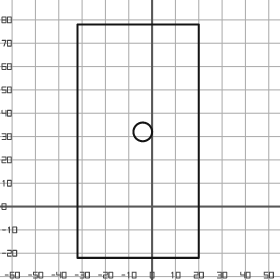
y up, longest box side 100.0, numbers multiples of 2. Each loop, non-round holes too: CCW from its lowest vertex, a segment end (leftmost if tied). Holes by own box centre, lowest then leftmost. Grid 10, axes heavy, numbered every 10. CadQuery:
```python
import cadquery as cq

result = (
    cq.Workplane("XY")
    .moveTo(-32.0, -22.0)
    .lineTo(20.0, -22.0)
    .lineTo(20.0, 78.0)
    .lineTo(-32.0, 78.0)
    .close()
    .moveTo(-4.0, 32.0)
    .circle(4.0)
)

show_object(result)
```